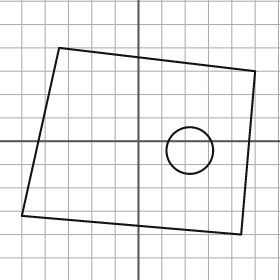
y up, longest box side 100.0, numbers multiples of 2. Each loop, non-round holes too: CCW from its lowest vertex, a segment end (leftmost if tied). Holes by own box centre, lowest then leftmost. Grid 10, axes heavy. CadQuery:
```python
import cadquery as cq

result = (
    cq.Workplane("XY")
    .moveTo(44.0, -40.0)
    .lineTo(50.0, 30.0)
    .lineTo(-34.0, 40.0)
    .lineTo(-50.0, -32.0)
    .close()
    .moveTo(22.0, -4.0)
    .circle(10.0)
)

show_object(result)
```